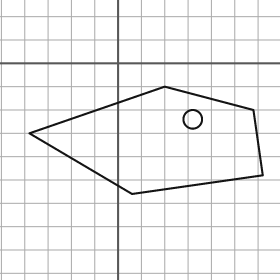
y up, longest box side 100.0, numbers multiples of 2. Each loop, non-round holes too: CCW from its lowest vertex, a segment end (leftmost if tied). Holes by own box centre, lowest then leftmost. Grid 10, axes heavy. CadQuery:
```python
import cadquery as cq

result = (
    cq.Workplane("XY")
    .moveTo(6.0, -56.0)
    .lineTo(62.0, -48.0)
    .lineTo(58.0, -20.0)
    .lineTo(20.0, -10.0)
    .lineTo(-38.0, -30.0)
    .close()
    .moveTo(32.0, -24.0)
    .circle(4.0)
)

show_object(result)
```